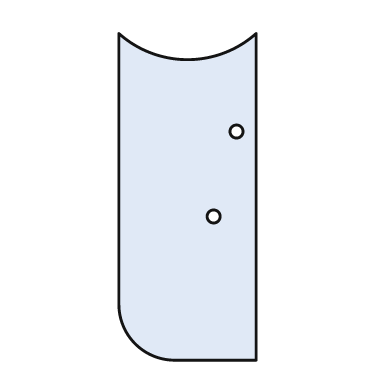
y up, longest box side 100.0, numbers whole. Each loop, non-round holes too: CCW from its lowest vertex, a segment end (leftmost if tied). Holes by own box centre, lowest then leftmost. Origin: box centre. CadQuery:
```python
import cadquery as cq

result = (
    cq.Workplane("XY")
    .moveTo(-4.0, -50.0)
    .lineTo(21.0, -50.0)
    .lineTo(21.0, 50.0)
    .threePointArc((0.0, 42.0), (-21.0, 50.0))
    .lineTo(-21.0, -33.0)
    .threePointArc((-16.0, -45.0), (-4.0, -50.0))
    .close()
    .moveTo(8.0, -6.0)
    .circle(2.0)
    .moveTo(15.0, 20.0)
    .circle(2.0)
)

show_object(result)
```